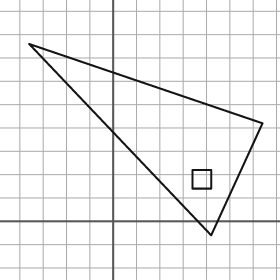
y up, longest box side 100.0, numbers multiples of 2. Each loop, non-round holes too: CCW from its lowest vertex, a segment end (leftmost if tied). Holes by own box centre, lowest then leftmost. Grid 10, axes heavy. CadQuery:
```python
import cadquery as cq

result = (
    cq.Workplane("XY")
    .moveTo(42.0, -6.0)
    .lineTo(64.0, 42.0)
    .lineTo(-36.0, 76.0)
    .close()
    .moveTo(34.0, 14.0)
    .lineTo(42.0, 14.0)
    .lineTo(42.0, 22.0)
    .lineTo(34.0, 22.0)
    .close()
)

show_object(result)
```